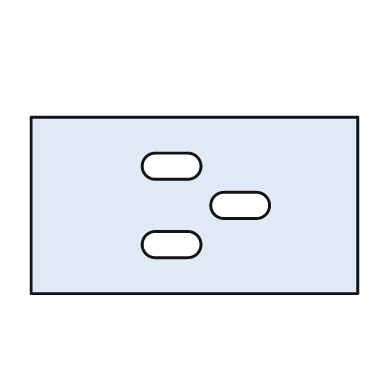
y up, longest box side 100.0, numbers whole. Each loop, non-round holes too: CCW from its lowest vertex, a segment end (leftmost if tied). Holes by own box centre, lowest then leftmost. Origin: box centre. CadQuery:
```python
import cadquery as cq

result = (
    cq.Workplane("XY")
    .moveTo(-50.0, -27.0)
    .lineTo(50.0, -27.0)
    .lineTo(50.0, 27.0)
    .lineTo(-50.0, 27.0)
    .close()
    .moveTo(-12.0, -16.0)
    .lineTo(-2.0, -16.0)
    .threePointArc((2.0, -12.0), (-2.0, -8.0))
    .lineTo(-12.0, -8.0)
    .threePointArc((-16.0, -12.0), (-12.0, -16.0))
    .close()
    .moveTo(9.0, -4.0)
    .lineTo(19.0, -4.0)
    .threePointArc((23.0, 0.0), (19.0, 4.0))
    .lineTo(9.0, 4.0)
    .threePointArc((5.0, 0.0), (9.0, -4.0))
    .close()
    .moveTo(-12.0, 8.0)
    .lineTo(-2.0, 8.0)
    .threePointArc((2.0, 12.0), (-2.0, 16.0))
    .lineTo(-12.0, 16.0)
    .threePointArc((-16.0, 12.0), (-12.0, 8.0))
    .close()
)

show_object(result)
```